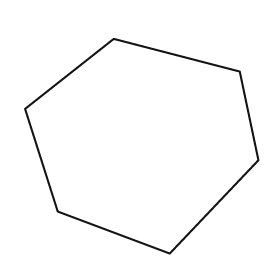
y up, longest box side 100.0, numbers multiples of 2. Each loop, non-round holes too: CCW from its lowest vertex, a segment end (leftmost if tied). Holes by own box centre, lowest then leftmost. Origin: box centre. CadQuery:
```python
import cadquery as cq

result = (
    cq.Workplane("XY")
    .moveTo(12.0, -46.0)
    .lineTo(50.0, -6.0)
    .lineTo(42.0, 32.0)
    .lineTo(-12.0, 46.0)
    .lineTo(-50.0, 16.0)
    .lineTo(-36.0, -28.0)
    .close()
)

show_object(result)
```